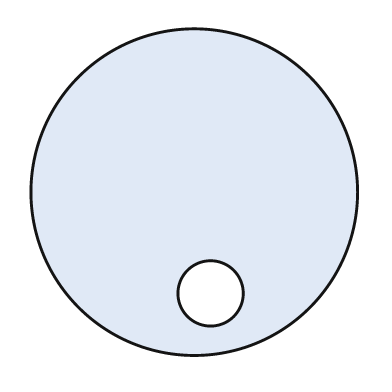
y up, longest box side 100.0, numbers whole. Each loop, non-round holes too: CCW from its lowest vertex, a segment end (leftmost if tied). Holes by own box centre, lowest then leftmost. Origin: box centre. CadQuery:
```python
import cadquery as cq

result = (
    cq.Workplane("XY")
    .moveTo(0.0, 0.0)
    .circle(50.0)
    .moveTo(5.0, -31.0)
    .circle(10.0)
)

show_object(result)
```